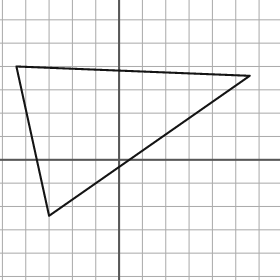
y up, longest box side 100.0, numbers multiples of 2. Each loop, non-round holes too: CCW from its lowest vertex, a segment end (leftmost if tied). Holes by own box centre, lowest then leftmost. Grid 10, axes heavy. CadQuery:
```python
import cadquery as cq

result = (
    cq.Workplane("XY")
    .moveTo(-30.0, -24.0)
    .lineTo(56.0, 36.0)
    .lineTo(-44.0, 40.0)
    .close()
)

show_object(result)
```